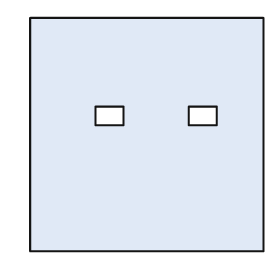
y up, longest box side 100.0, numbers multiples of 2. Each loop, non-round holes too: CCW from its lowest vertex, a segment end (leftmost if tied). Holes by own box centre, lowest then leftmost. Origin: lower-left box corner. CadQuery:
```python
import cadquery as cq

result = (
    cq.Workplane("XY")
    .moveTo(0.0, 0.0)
    .lineTo(100.0, 0.0)
    .lineTo(100.0, 100.0)
    .lineTo(0.0, 100.0)
    .close()
    .moveTo(28.0, 54.0)
    .lineTo(40.0, 54.0)
    .lineTo(40.0, 62.0)
    .lineTo(28.0, 62.0)
    .close()
    .moveTo(68.0, 54.0)
    .lineTo(80.0, 54.0)
    .lineTo(80.0, 62.0)
    .lineTo(68.0, 62.0)
    .close()
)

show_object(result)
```